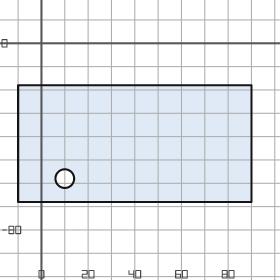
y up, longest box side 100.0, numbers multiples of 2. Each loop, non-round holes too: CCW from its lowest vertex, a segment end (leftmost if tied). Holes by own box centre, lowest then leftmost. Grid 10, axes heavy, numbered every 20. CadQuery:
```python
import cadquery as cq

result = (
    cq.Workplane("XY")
    .moveTo(-10.0, -68.0)
    .lineTo(90.0, -68.0)
    .lineTo(90.0, -18.0)
    .lineTo(-10.0, -18.0)
    .close()
    .moveTo(10.0, -58.0)
    .circle(4.0)
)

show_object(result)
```